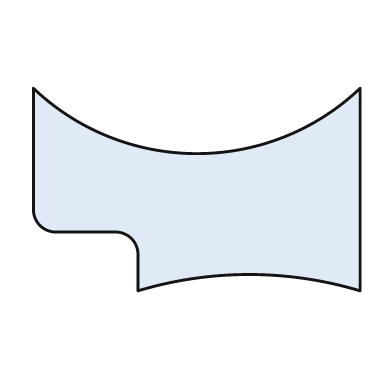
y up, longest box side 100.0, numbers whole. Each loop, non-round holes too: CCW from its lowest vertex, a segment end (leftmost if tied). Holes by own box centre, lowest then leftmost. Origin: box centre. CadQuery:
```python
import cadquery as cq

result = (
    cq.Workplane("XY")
    .moveTo(-18.0, -31.0)
    .threePointArc((16.0, -26.0), (50.0, -31.0))
    .lineTo(50.0, 31.0)
    .threePointArc((0.0, 11.0), (-50.0, 31.0))
    .lineTo(-50.0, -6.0)
    .threePointArc((-48.0, -11.0), (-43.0, -13.0))
    .lineTo(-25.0, -13.0)
    .threePointArc((-20.0, -15.0), (-18.0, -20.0))
    .close()
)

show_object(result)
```